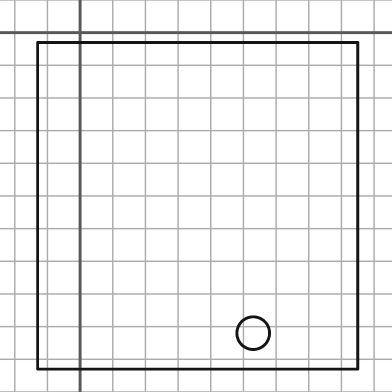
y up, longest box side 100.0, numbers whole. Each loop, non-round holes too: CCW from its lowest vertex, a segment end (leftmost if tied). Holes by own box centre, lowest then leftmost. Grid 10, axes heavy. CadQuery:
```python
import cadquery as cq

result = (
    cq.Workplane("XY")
    .moveTo(-13.0, -103.0)
    .lineTo(85.0, -103.0)
    .lineTo(85.0, -3.0)
    .lineTo(-13.0, -3.0)
    .close()
    .moveTo(53.0, -92.0)
    .circle(5.0)
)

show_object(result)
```